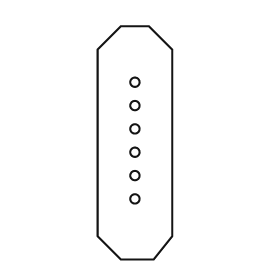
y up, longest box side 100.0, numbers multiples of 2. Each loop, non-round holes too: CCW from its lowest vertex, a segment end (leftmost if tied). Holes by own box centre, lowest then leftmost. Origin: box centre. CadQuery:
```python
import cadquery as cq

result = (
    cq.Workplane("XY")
    .moveTo(-6.0, -50.0)
    .lineTo(8.0, -50.0)
    .lineTo(16.0, -40.0)
    .lineTo(16.0, 40.0)
    .lineTo(6.0, 50.0)
    .lineTo(-6.0, 50.0)
    .lineTo(-16.0, 40.0)
    .lineTo(-16.0, -40.0)
    .close()
    .moveTo(0.0, -24.0)
    .circle(2.0)
    .moveTo(0.0, -14.0)
    .circle(2.0)
    .moveTo(0.0, -4.0)
    .circle(2.0)
    .moveTo(0.0, 6.0)
    .circle(2.0)
    .moveTo(0.0, 16.0)
    .circle(2.0)
    .moveTo(0.0, 26.0)
    .circle(2.0)
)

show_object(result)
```